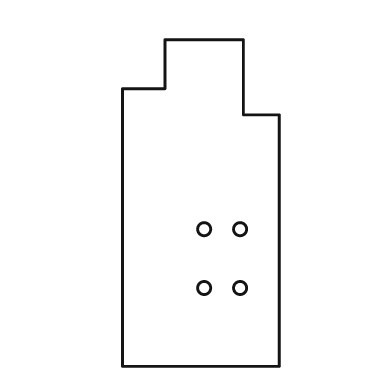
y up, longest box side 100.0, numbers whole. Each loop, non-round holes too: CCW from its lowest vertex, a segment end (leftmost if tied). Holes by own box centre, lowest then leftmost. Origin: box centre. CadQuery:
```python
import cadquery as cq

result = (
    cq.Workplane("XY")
    .moveTo(-24.0, -50.0)
    .lineTo(24.0, -50.0)
    .lineTo(24.0, 27.0)
    .lineTo(13.0, 27.0)
    .lineTo(13.0, 50.0)
    .lineTo(-11.0, 50.0)
    .lineTo(-11.0, 35.0)
    .lineTo(-24.0, 35.0)
    .close()
    .moveTo(1.0, -26.0)
    .circle(2.0)
    .moveTo(12.0, -26.0)
    .circle(2.0)
    .moveTo(1.0, -8.0)
    .circle(2.0)
    .moveTo(12.0, -8.0)
    .circle(2.0)
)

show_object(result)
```